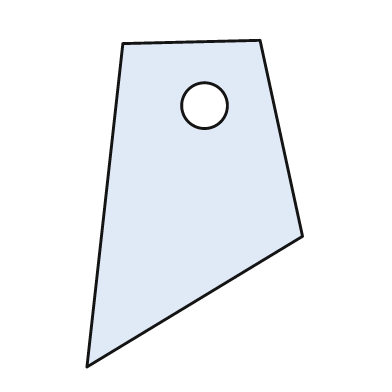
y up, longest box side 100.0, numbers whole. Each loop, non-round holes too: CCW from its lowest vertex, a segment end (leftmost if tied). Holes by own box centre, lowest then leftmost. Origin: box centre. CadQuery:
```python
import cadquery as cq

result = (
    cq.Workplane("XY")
    .moveTo(-33.0, -50.0)
    .lineTo(33.0, -10.0)
    .lineTo(20.0, 50.0)
    .lineTo(-22.0, 49.0)
    .close()
    .moveTo(3.0, 30.0)
    .circle(7.0)
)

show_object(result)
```